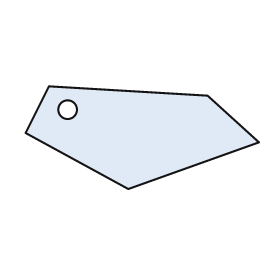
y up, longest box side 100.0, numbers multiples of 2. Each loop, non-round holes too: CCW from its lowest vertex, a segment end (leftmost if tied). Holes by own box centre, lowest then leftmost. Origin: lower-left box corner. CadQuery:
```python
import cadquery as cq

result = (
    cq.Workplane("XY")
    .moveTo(44.0, 0.0)
    .lineTo(100.0, 20.0)
    .lineTo(78.0, 40.0)
    .lineTo(10.0, 44.0)
    .lineTo(0.0, 24.0)
    .close()
    .moveTo(18.0, 34.0)
    .circle(4.0)
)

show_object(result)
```